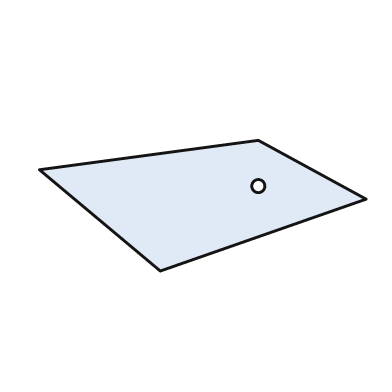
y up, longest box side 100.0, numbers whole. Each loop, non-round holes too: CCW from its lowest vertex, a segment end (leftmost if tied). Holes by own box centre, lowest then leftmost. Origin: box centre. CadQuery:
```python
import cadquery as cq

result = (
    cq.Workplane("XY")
    .moveTo(-13.0, -20.0)
    .lineTo(50.0, 2.0)
    .lineTo(17.0, 20.0)
    .lineTo(-50.0, 11.0)
    .close()
    .moveTo(17.0, 6.0)
    .circle(2.0)
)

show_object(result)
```